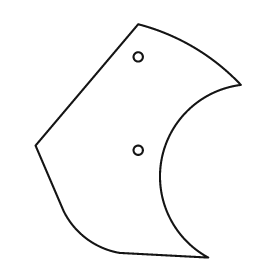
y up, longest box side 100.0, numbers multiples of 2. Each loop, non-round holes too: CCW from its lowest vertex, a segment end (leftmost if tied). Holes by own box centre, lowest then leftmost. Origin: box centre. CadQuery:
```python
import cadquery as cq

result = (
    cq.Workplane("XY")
    .moveTo(30.0, -50.0)
    .threePointArc((10.0, -8.0), (44.0, 24.0))
    .threePointArc((24.0, 40.0), (0.0, 50.0))
    .lineTo(-44.0, -2.0)
    .lineTo(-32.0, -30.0)
    .threePointArc((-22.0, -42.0), (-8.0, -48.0))
    .close()
    .moveTo(0.0, -4.0)
    .circle(2.0)
    .moveTo(0.0, 36.0)
    .circle(2.0)
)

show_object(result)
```